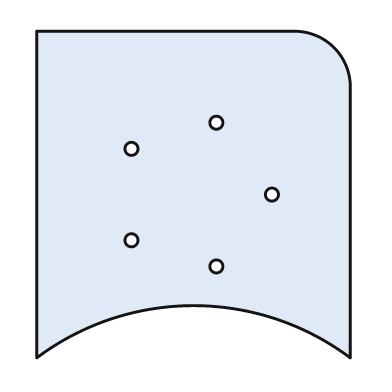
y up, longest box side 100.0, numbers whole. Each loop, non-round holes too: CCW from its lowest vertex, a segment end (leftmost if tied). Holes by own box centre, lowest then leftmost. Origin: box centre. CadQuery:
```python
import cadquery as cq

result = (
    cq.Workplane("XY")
    .moveTo(-48.0, -50.0)
    .threePointArc((0.0, -34.0), (48.0, -50.0))
    .lineTo(48.0, 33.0)
    .threePointArc((43.0, 45.0), (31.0, 50.0))
    .lineTo(-48.0, 50.0)
    .close()
    .moveTo(7.0, -22.0)
    .circle(2.0)
    .moveTo(-19.0, -14.0)
    .circle(2.0)
    .moveTo(24.0, 0.0)
    .circle(2.0)
    .moveTo(-19.0, 14.0)
    .circle(2.0)
    .moveTo(7.0, 22.0)
    .circle(2.0)
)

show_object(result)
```